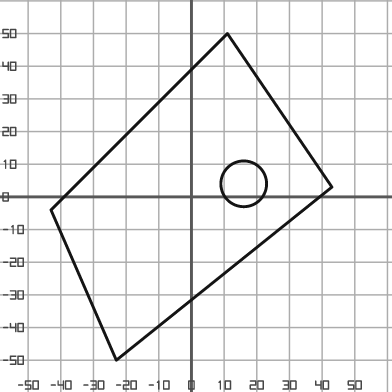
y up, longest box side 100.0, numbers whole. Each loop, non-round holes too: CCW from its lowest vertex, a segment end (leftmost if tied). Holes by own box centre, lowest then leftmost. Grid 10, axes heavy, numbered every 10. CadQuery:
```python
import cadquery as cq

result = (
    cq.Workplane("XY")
    .moveTo(-23.0, -50.0)
    .lineTo(43.0, 3.0)
    .lineTo(11.0, 50.0)
    .lineTo(-43.0, -4.0)
    .close()
    .moveTo(16.0, 4.0)
    .circle(7.0)
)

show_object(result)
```